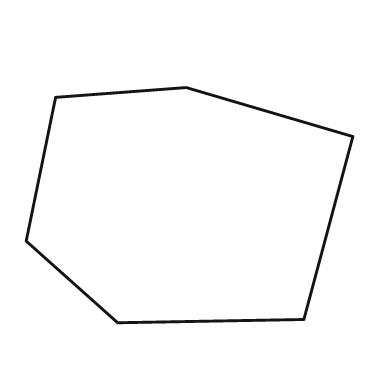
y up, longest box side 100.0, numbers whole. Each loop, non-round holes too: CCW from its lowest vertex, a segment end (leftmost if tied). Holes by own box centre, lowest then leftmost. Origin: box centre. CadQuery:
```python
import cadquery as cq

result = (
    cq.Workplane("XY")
    .moveTo(-22.0, -36.0)
    .lineTo(35.0, -35.0)
    .lineTo(50.0, 21.0)
    .lineTo(-1.0, 36.0)
    .lineTo(-41.0, 33.0)
    .lineTo(-50.0, -11.0)
    .close()
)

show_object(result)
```